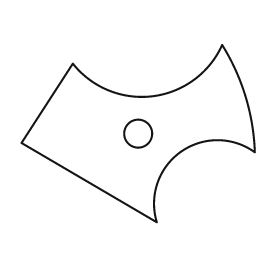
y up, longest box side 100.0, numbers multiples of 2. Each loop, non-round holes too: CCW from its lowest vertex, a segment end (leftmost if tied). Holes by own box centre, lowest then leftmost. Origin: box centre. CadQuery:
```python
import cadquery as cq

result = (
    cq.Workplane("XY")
    .moveTo(8.0, -38.0)
    .threePointArc((18.0, -8.0), (50.0, -8.0))
    .threePointArc((46.0, 16.0), (36.0, 38.0))
    .threePointArc((6.0, 16.0), (-28.0, 30.0))
    .lineTo(-50.0, -4.0)
    .close()
    .moveTo(0.0, 0.0)
    .circle(6.0)
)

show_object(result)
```